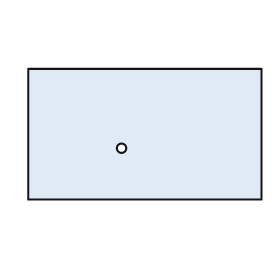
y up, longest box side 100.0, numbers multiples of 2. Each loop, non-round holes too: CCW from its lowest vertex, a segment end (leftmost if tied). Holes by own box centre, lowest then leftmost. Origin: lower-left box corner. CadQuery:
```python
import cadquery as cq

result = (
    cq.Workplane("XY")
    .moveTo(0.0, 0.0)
    .lineTo(100.0, 0.0)
    .lineTo(100.0, 56.0)
    .lineTo(0.0, 56.0)
    .close()
    .moveTo(40.0, 22.0)
    .circle(2.0)
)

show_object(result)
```